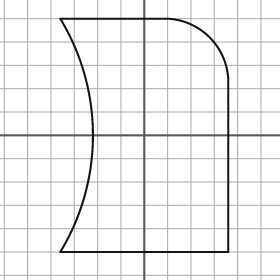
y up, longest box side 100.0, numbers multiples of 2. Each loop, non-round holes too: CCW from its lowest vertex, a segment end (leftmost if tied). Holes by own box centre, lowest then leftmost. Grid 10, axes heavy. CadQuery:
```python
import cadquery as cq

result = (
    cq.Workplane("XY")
    .moveTo(-36.0, -50.0)
    .lineTo(36.0, -50.0)
    .lineTo(36.0, 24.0)
    .threePointArc((28.0, 42.0), (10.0, 50.0))
    .lineTo(-36.0, 50.0)
    .threePointArc((-22.0, 0.0), (-36.0, -50.0))
    .close()
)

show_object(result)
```